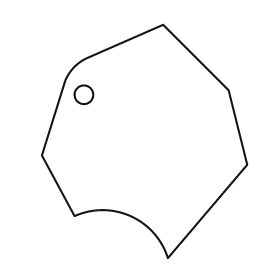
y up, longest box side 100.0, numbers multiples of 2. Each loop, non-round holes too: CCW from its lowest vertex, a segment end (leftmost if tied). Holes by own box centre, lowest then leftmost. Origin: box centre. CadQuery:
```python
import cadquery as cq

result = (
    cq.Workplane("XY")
    .moveTo(10.0, -50.0)
    .lineTo(44.0, -10.0)
    .lineTo(36.0, 22.0)
    .lineTo(8.0, 50.0)
    .lineTo(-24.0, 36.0)
    .threePointArc((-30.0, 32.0), (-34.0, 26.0))
    .lineTo(-44.0, -6.0)
    .lineTo(-30.0, -32.0)
    .threePointArc((-6.0, -32.0), (10.0, -50.0))
    .close()
    .moveTo(-26.0, 20.0)
    .circle(4.0)
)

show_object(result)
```